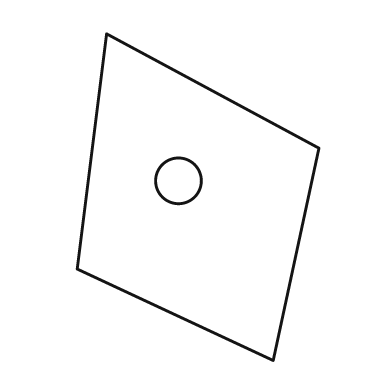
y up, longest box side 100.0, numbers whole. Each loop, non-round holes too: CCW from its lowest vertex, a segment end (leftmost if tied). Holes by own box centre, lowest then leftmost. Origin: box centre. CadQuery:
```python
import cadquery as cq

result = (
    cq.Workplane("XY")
    .moveTo(23.0, -50.0)
    .lineTo(37.0, 15.0)
    .lineTo(-28.0, 50.0)
    .lineTo(-37.0, -22.0)
    .close()
    .moveTo(-6.0, 5.0)
    .circle(7.0)
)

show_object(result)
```